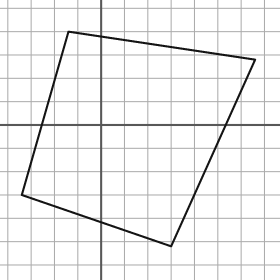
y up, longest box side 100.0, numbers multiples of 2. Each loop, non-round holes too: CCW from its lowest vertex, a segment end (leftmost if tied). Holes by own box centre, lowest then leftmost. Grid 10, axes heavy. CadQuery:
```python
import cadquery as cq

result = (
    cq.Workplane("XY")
    .moveTo(30.0, -52.0)
    .lineTo(66.0, 28.0)
    .lineTo(-14.0, 40.0)
    .lineTo(-34.0, -30.0)
    .close()
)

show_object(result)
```